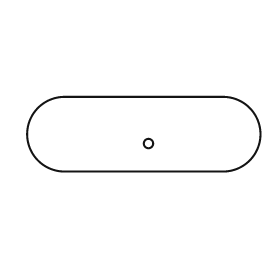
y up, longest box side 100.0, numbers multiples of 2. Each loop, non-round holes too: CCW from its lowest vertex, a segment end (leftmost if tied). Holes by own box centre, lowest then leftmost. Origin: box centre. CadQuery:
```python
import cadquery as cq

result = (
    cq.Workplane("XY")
    .moveTo(-34.0, -16.0)
    .lineTo(34.0, -16.0)
    .threePointArc((50.0, 0.0), (34.0, 16.0))
    .lineTo(-34.0, 16.0)
    .threePointArc((-50.0, 0.0), (-34.0, -16.0))
    .close()
    .moveTo(2.0, -4.0)
    .circle(2.0)
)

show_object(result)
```